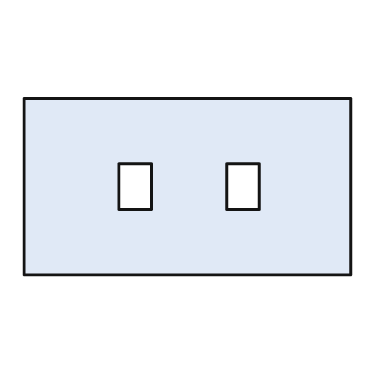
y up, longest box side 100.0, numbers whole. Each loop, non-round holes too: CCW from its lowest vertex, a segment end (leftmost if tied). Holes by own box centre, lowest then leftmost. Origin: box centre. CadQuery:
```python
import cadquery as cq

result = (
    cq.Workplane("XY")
    .moveTo(-50.0, -27.0)
    .lineTo(50.0, -27.0)
    .lineTo(50.0, 27.0)
    .lineTo(-50.0, 27.0)
    .close()
    .moveTo(-21.0, -7.0)
    .lineTo(-11.0, -7.0)
    .lineTo(-11.0, 7.0)
    .lineTo(-21.0, 7.0)
    .close()
    .moveTo(12.0, -7.0)
    .lineTo(22.0, -7.0)
    .lineTo(22.0, 7.0)
    .lineTo(12.0, 7.0)
    .close()
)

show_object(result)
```